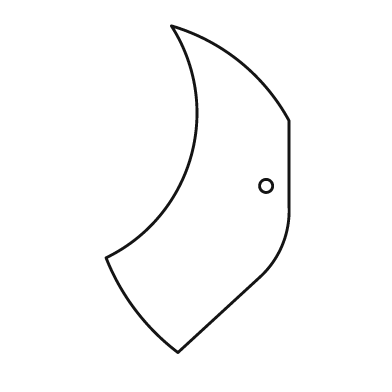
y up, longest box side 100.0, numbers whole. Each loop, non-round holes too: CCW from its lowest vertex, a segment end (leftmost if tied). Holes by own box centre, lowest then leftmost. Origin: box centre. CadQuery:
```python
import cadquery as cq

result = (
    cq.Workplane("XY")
    .moveTo(-6.0, -50.0)
    .lineTo(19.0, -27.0)
    .threePointArc((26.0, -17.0), (28.0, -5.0))
    .lineTo(28.0, 21.0)
    .threePointArc((13.0, 39.0), (-8.0, 50.0))
    .threePointArc((-2.0, 10.0), (-28.0, -21.0))
    .threePointArc((-19.0, -37.0), (-6.0, -50.0))
    .close()
    .moveTo(21.0, 1.0)
    .circle(2.0)
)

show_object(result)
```